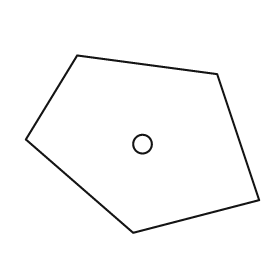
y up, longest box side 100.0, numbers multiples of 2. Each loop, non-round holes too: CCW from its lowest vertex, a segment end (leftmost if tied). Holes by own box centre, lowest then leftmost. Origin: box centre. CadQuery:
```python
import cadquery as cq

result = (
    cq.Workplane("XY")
    .moveTo(-4.0, -38.0)
    .lineTo(50.0, -24.0)
    .lineTo(32.0, 30.0)
    .lineTo(-28.0, 38.0)
    .lineTo(-50.0, 2.0)
    .close()
    .moveTo(0.0, 0.0)
    .circle(4.0)
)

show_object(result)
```